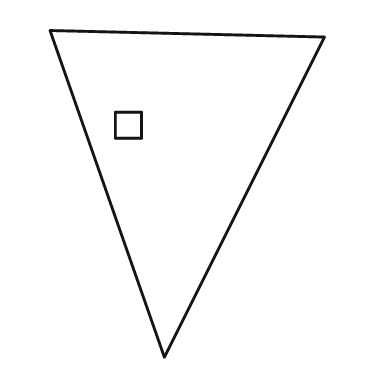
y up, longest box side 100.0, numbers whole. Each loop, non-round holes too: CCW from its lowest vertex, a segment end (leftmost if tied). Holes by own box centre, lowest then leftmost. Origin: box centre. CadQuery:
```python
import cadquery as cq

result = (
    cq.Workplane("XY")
    .moveTo(-7.0, -50.0)
    .lineTo(42.0, 48.0)
    .lineTo(-42.0, 50.0)
    .close()
    .moveTo(-22.0, 17.0)
    .lineTo(-14.0, 17.0)
    .lineTo(-14.0, 25.0)
    .lineTo(-22.0, 25.0)
    .close()
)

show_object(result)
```